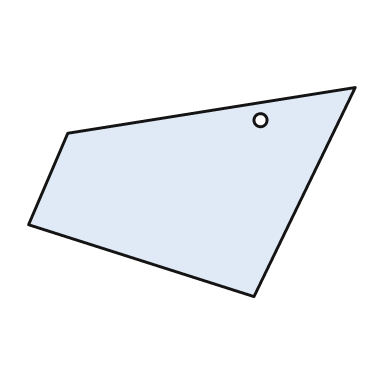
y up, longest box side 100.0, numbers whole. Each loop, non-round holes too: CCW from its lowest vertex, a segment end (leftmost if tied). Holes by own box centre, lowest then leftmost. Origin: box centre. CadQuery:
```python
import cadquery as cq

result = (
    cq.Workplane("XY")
    .moveTo(19.0, -32.0)
    .lineTo(50.0, 32.0)
    .lineTo(-38.0, 18.0)
    .lineTo(-50.0, -10.0)
    .close()
    .moveTo(21.0, 22.0)
    .circle(2.0)
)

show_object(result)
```